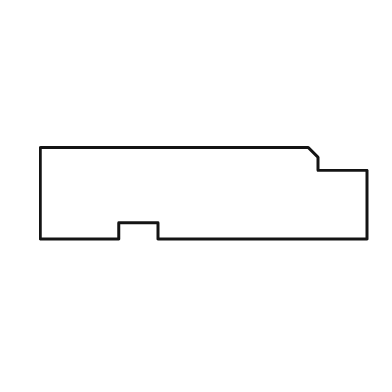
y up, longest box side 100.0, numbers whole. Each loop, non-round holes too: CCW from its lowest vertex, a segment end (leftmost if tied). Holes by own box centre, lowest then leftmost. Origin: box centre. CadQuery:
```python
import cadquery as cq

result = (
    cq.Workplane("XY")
    .moveTo(-50.0, -14.0)
    .lineTo(-26.0, -14.0)
    .lineTo(-26.0, -9.0)
    .lineTo(-14.0, -9.0)
    .lineTo(-14.0, -14.0)
    .lineTo(50.0, -14.0)
    .lineTo(50.0, 7.0)
    .lineTo(35.0, 7.0)
    .lineTo(35.0, 11.0)
    .lineTo(32.0, 14.0)
    .lineTo(-50.0, 14.0)
    .close()
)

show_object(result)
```